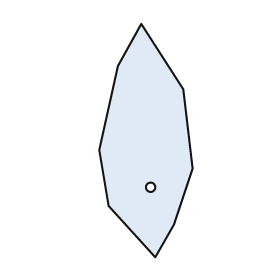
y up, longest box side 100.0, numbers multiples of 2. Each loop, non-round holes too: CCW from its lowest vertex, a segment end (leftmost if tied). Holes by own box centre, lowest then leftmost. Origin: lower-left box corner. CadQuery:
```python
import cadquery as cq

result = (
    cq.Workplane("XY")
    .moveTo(24.0, 0.0)
    .lineTo(32.0, 14.0)
    .lineTo(40.0, 38.0)
    .lineTo(36.0, 72.0)
    .lineTo(18.0, 100.0)
    .lineTo(8.0, 82.0)
    .lineTo(0.0, 46.0)
    .lineTo(4.0, 22.0)
    .close()
    .moveTo(22.0, 30.0)
    .circle(2.0)
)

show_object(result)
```